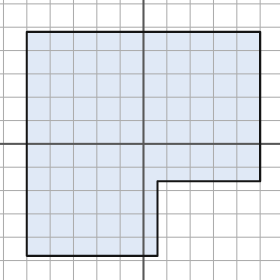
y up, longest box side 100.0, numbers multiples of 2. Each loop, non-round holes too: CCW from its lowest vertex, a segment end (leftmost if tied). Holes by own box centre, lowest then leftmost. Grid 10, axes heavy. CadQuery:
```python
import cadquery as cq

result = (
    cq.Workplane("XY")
    .moveTo(-50.0, -48.0)
    .lineTo(6.0, -48.0)
    .lineTo(6.0, -16.0)
    .lineTo(50.0, -16.0)
    .lineTo(50.0, 48.0)
    .lineTo(-50.0, 48.0)
    .close()
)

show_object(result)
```